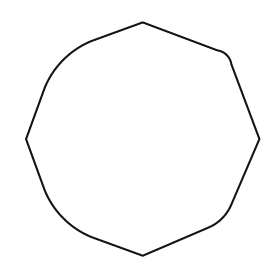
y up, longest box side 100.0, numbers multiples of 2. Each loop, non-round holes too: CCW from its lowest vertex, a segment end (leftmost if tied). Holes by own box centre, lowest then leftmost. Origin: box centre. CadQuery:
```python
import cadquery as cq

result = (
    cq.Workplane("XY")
    .moveTo(0.0, -50.0)
    .lineTo(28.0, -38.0)
    .threePointArc((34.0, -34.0), (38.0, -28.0))
    .lineTo(50.0, 0.0)
    .lineTo(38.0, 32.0)
    .threePointArc((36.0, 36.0), (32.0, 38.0))
    .lineTo(0.0, 50.0)
    .lineTo(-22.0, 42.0)
    .threePointArc((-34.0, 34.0), (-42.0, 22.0))
    .lineTo(-50.0, 0.0)
    .lineTo(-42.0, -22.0)
    .threePointArc((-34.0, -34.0), (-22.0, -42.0))
    .close()
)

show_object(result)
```